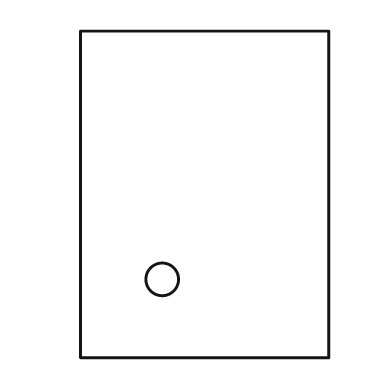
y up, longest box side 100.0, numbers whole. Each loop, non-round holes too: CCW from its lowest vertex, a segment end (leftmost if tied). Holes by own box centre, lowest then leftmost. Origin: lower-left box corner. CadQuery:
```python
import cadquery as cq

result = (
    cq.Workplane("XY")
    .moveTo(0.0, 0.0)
    .lineTo(76.0, 0.0)
    .lineTo(76.0, 100.0)
    .lineTo(0.0, 100.0)
    .close()
    .moveTo(25.0, 24.0)
    .circle(5.0)
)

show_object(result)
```